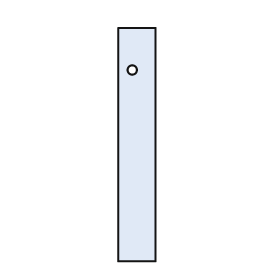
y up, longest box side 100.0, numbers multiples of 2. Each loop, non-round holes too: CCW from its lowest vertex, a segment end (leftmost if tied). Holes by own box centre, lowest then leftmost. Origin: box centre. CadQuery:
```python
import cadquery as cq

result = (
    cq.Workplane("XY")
    .moveTo(-8.0, -50.0)
    .lineTo(8.0, -50.0)
    .lineTo(8.0, 50.0)
    .lineTo(-8.0, 50.0)
    .close()
    .moveTo(-2.0, 32.0)
    .circle(2.0)
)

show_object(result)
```